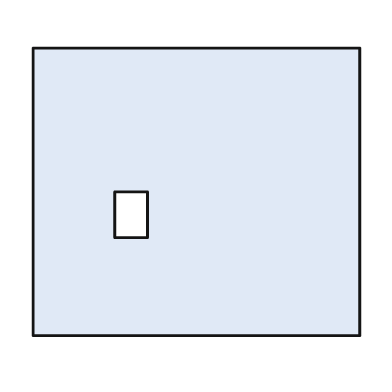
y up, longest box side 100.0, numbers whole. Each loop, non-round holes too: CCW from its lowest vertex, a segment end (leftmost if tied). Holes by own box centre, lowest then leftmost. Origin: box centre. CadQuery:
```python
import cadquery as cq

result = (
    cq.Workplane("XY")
    .moveTo(-50.0, -44.0)
    .lineTo(50.0, -44.0)
    .lineTo(50.0, 44.0)
    .lineTo(-50.0, 44.0)
    .close()
    .moveTo(-25.0, -14.0)
    .lineTo(-15.0, -14.0)
    .lineTo(-15.0, 0.0)
    .lineTo(-25.0, 0.0)
    .close()
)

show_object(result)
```